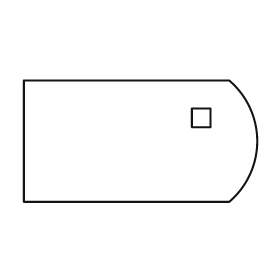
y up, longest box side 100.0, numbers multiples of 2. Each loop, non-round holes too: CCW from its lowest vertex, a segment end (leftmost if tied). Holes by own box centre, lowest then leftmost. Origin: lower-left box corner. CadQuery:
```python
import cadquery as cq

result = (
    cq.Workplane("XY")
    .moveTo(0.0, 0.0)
    .lineTo(88.0, 0.0)
    .threePointArc((100.0, 26.0), (88.0, 52.0))
    .lineTo(0.0, 52.0)
    .close()
    .moveTo(72.0, 32.0)
    .lineTo(80.0, 32.0)
    .lineTo(80.0, 40.0)
    .lineTo(72.0, 40.0)
    .close()
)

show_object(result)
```